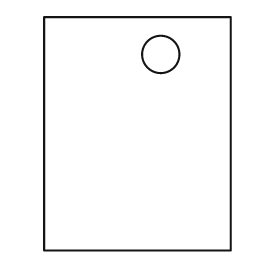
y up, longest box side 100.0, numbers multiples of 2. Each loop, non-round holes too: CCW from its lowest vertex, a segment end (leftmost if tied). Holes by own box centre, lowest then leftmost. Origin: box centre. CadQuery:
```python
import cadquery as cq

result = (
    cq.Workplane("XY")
    .moveTo(-40.0, -50.0)
    .lineTo(40.0, -50.0)
    .lineTo(40.0, 50.0)
    .lineTo(-40.0, 50.0)
    .close()
    .moveTo(10.0, 34.0)
    .circle(8.0)
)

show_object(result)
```